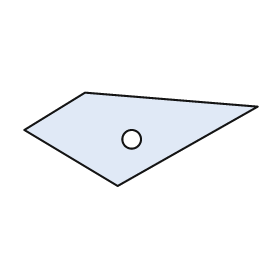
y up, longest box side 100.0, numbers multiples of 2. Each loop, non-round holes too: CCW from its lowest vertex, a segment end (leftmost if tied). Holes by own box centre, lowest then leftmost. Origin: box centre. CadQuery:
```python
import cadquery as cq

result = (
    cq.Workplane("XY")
    .moveTo(-10.0, -20.0)
    .lineTo(50.0, 14.0)
    .lineTo(-24.0, 20.0)
    .lineTo(-50.0, 4.0)
    .close()
    .moveTo(-4.0, 0.0)
    .circle(4.0)
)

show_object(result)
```